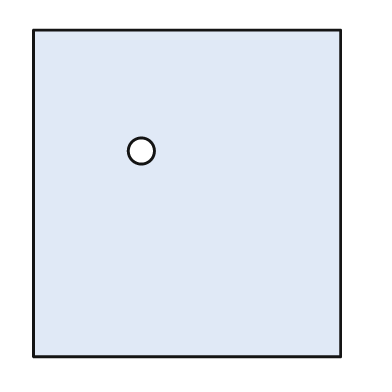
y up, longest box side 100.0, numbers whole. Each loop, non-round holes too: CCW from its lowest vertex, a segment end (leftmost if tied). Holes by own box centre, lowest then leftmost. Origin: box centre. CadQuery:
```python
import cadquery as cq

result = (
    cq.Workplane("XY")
    .moveTo(-47.0, -50.0)
    .lineTo(47.0, -50.0)
    .lineTo(47.0, 50.0)
    .lineTo(-47.0, 50.0)
    .close()
    .moveTo(-14.0, 13.0)
    .circle(4.0)
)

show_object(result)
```